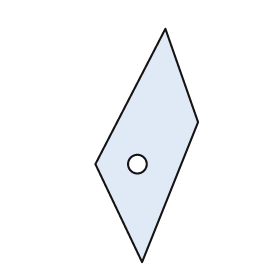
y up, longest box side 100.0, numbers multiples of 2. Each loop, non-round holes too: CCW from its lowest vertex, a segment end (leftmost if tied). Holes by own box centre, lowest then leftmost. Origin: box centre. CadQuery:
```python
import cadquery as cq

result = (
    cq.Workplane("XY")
    .moveTo(-2.0, -50.0)
    .lineTo(22.0, 10.0)
    .lineTo(8.0, 50.0)
    .lineTo(-22.0, -8.0)
    .close()
    .moveTo(-4.0, -8.0)
    .circle(4.0)
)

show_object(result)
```